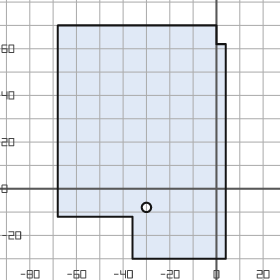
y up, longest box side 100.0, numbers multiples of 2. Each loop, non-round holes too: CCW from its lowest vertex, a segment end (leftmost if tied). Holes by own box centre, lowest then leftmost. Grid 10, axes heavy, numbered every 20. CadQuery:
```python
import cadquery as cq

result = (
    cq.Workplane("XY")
    .moveTo(-36.0, -30.0)
    .lineTo(4.0, -30.0)
    .lineTo(4.0, 62.0)
    .lineTo(0.0, 62.0)
    .lineTo(0.0, 70.0)
    .lineTo(-68.0, 70.0)
    .lineTo(-68.0, -12.0)
    .lineTo(-36.0, -12.0)
    .close()
    .moveTo(-30.0, -8.0)
    .circle(2.0)
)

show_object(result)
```